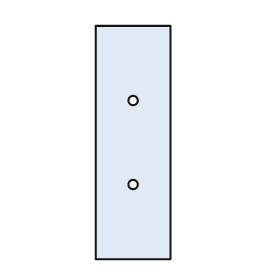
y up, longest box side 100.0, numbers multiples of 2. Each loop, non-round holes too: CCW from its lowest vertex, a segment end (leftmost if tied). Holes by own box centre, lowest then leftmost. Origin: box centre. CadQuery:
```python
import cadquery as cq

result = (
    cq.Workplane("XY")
    .moveTo(-16.0, -50.0)
    .lineTo(16.0, -50.0)
    .lineTo(16.0, 50.0)
    .lineTo(-16.0, 50.0)
    .close()
    .moveTo(0.0, -18.0)
    .circle(2.0)
    .moveTo(0.0, 18.0)
    .circle(2.0)
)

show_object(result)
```